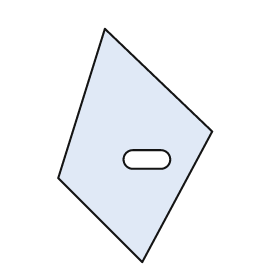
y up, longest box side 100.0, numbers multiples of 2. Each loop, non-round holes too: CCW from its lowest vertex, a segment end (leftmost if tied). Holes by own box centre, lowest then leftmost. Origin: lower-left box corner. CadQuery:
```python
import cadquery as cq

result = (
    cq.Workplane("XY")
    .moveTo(36.0, 0.0)
    .lineTo(66.0, 56.0)
    .lineTo(20.0, 100.0)
    .lineTo(0.0, 36.0)
    .close()
    .moveTo(32.0, 40.0)
    .lineTo(44.0, 40.0)
    .threePointArc((48.0, 44.0), (44.0, 48.0))
    .lineTo(32.0, 48.0)
    .threePointArc((28.0, 44.0), (32.0, 40.0))
    .close()
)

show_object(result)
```